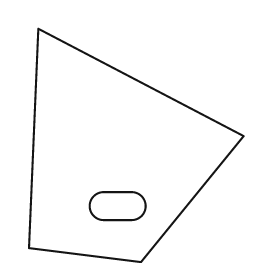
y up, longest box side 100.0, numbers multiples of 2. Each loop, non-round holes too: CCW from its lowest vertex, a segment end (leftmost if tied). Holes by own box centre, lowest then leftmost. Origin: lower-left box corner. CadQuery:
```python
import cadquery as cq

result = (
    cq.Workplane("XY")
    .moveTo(48.0, 0.0)
    .lineTo(92.0, 54.0)
    .lineTo(4.0, 100.0)
    .lineTo(0.0, 6.0)
    .close()
    .moveTo(32.0, 18.0)
    .lineTo(44.0, 18.0)
    .threePointArc((50.0, 24.0), (44.0, 30.0))
    .lineTo(32.0, 30.0)
    .threePointArc((26.0, 24.0), (32.0, 18.0))
    .close()
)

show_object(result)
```